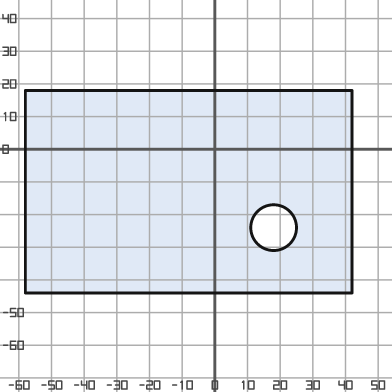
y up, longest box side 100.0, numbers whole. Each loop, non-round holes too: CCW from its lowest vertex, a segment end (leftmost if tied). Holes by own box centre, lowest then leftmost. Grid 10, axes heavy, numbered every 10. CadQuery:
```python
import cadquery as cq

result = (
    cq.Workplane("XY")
    .moveTo(-58.0, -44.0)
    .lineTo(42.0, -44.0)
    .lineTo(42.0, 18.0)
    .lineTo(-58.0, 18.0)
    .close()
    .moveTo(18.0, -24.0)
    .circle(7.0)
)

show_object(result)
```